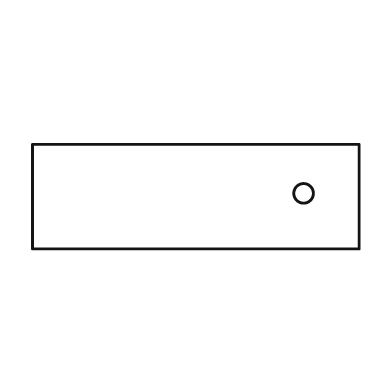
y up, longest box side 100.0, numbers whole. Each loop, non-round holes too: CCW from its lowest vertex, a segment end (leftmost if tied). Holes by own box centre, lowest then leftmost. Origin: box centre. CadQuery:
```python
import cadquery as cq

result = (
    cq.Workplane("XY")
    .moveTo(-50.0, -16.0)
    .lineTo(50.0, -16.0)
    .lineTo(50.0, 16.0)
    .lineTo(-50.0, 16.0)
    .close()
    .moveTo(33.0, 1.0)
    .circle(3.0)
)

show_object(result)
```